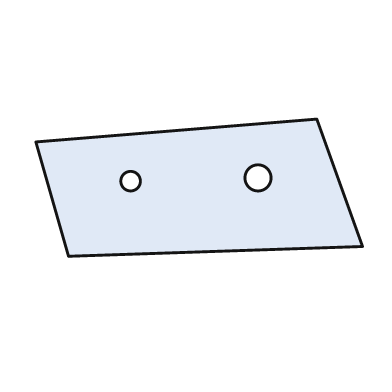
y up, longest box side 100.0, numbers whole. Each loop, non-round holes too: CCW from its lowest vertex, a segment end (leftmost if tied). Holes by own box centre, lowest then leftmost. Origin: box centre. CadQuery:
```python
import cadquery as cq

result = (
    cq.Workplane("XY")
    .moveTo(-40.0, -21.0)
    .lineTo(50.0, -18.0)
    .lineTo(36.0, 21.0)
    .lineTo(-50.0, 14.0)
    .close()
    .moveTo(-21.0, 2.0)
    .circle(3.0)
    .moveTo(18.0, 3.0)
    .circle(4.0)
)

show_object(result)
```